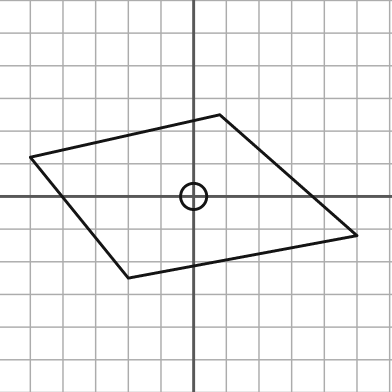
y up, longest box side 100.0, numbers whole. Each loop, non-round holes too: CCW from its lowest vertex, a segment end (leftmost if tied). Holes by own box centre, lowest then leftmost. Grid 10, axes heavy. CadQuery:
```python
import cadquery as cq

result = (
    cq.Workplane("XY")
    .moveTo(-20.0, -25.0)
    .lineTo(50.0, -12.0)
    .lineTo(8.0, 25.0)
    .lineTo(-50.0, 12.0)
    .close()
    .moveTo(0.0, 0.0)
    .circle(4.0)
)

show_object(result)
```